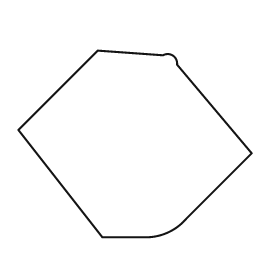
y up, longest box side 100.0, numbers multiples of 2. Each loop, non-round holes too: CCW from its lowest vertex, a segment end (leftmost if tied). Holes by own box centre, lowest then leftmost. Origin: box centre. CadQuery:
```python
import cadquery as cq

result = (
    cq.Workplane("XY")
    .moveTo(-14.0, -40.0)
    .lineTo(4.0, -40.0)
    .threePointArc((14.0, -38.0), (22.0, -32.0))
    .lineTo(50.0, -4.0)
    .lineTo(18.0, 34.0)
    .threePointArc((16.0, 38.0), (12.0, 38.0))
    .lineTo(-16.0, 40.0)
    .lineTo(-50.0, 6.0)
    .close()
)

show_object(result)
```